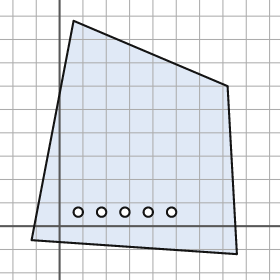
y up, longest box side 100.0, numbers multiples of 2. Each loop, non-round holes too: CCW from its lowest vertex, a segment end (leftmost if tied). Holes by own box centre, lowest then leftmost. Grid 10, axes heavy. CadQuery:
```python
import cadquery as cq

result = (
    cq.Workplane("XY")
    .moveTo(76.0, -12.0)
    .lineTo(72.0, 60.0)
    .lineTo(6.0, 88.0)
    .lineTo(-12.0, -6.0)
    .close()
    .moveTo(8.0, 6.0)
    .circle(2.0)
    .moveTo(18.0, 6.0)
    .circle(2.0)
    .moveTo(28.0, 6.0)
    .circle(2.0)
    .moveTo(38.0, 6.0)
    .circle(2.0)
    .moveTo(48.0, 6.0)
    .circle(2.0)
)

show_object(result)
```